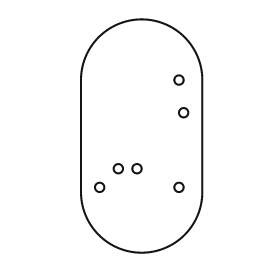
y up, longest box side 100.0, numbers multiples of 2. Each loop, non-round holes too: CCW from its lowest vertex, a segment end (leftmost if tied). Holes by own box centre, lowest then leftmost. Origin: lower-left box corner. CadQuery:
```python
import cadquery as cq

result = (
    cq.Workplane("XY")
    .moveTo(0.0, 26.0)
    .threePointArc((26.0, 0.0), (52.0, 26.0))
    .lineTo(52.0, 74.0)
    .threePointArc((26.0, 100.0), (0.0, 74.0))
    .close()
    .moveTo(8.0, 28.0)
    .circle(2.0)
    .moveTo(42.0, 28.0)
    .circle(2.0)
    .moveTo(16.0, 36.0)
    .circle(2.0)
    .moveTo(24.0, 36.0)
    .circle(2.0)
    .moveTo(44.0, 60.0)
    .circle(2.0)
    .moveTo(42.0, 74.0)
    .circle(2.0)
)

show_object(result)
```